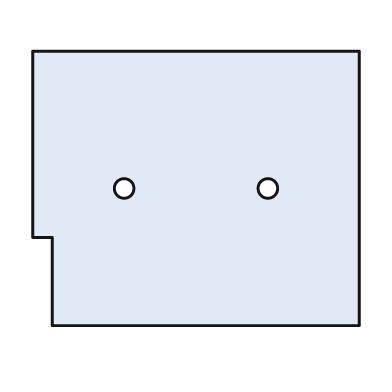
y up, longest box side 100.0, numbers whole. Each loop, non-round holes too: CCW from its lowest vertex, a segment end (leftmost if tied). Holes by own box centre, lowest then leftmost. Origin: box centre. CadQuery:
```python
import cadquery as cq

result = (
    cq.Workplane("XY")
    .moveTo(-44.0, -42.0)
    .lineTo(50.0, -42.0)
    .lineTo(50.0, 42.0)
    .lineTo(-50.0, 42.0)
    .lineTo(-50.0, -15.0)
    .lineTo(-44.0, -15.0)
    .close()
    .moveTo(-22.0, 0.0)
    .circle(3.0)
    .moveTo(22.0, 0.0)
    .circle(3.0)
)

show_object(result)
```